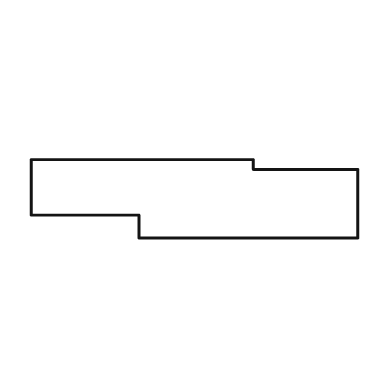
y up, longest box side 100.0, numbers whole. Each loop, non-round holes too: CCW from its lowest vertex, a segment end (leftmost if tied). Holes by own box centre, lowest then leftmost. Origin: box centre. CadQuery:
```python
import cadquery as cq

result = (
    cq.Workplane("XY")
    .moveTo(-17.0, -12.0)
    .lineTo(50.0, -12.0)
    .lineTo(50.0, 9.0)
    .lineTo(18.0, 9.0)
    .lineTo(18.0, 12.0)
    .lineTo(-50.0, 12.0)
    .lineTo(-50.0, -5.0)
    .lineTo(-17.0, -5.0)
    .close()
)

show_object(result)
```